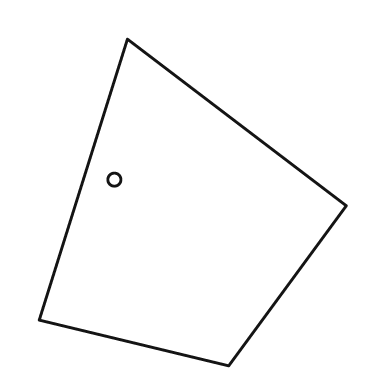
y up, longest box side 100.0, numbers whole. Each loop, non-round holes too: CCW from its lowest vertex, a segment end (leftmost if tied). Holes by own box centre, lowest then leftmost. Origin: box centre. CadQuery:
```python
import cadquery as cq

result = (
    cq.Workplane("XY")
    .moveTo(11.0, -50.0)
    .lineTo(47.0, -1.0)
    .lineTo(-20.0, 50.0)
    .lineTo(-47.0, -36.0)
    .close()
    .moveTo(-24.0, 7.0)
    .circle(2.0)
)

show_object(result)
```